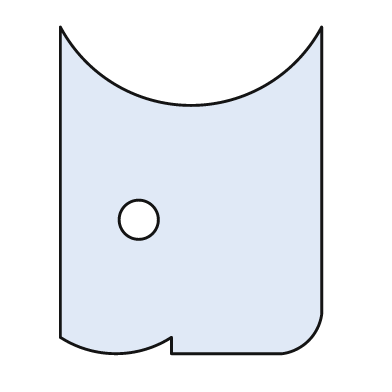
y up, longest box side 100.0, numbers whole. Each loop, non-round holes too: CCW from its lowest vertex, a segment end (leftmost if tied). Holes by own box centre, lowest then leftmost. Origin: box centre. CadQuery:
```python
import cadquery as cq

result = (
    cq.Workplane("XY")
    .moveTo(-6.0, -50.0)
    .lineTo(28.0, -50.0)
    .threePointArc((36.0, -46.0), (40.0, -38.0))
    .lineTo(40.0, 50.0)
    .threePointArc((0.0, 26.0), (-40.0, 50.0))
    .lineTo(-40.0, -45.0)
    .threePointArc((-23.0, -50.0), (-6.0, -45.0))
    .close()
    .moveTo(-16.0, -9.0)
    .circle(6.0)
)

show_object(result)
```